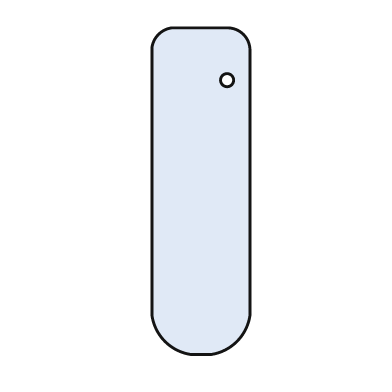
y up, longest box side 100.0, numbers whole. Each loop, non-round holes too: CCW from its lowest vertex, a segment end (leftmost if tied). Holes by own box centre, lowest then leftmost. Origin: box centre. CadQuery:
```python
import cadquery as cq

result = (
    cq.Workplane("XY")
    .moveTo(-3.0, -50.0)
    .lineTo(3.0, -50.0)
    .threePointArc((11.0, -46.0), (15.0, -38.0))
    .lineTo(15.0, 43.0)
    .threePointArc((13.0, 48.0), (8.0, 50.0))
    .lineTo(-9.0, 50.0)
    .threePointArc((-13.0, 48.0), (-15.0, 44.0))
    .lineTo(-15.0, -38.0)
    .threePointArc((-11.0, -46.0), (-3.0, -50.0))
    .close()
    .moveTo(8.0, 34.0)
    .circle(2.0)
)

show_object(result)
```